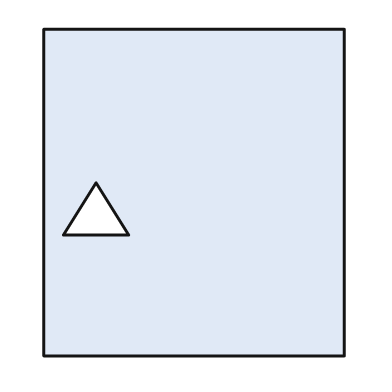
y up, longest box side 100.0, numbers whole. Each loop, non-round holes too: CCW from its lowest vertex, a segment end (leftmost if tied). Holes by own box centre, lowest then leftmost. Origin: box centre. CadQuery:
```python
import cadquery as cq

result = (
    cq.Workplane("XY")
    .moveTo(-46.0, -50.0)
    .lineTo(46.0, -50.0)
    .lineTo(46.0, 50.0)
    .lineTo(-46.0, 50.0)
    .close()
    .moveTo(-40.0, -13.0)
    .lineTo(-20.0, -13.0)
    .lineTo(-30.0, 3.0)
    .close()
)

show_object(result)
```